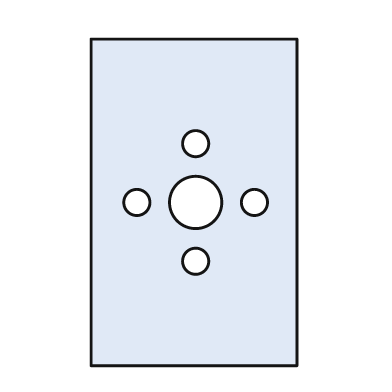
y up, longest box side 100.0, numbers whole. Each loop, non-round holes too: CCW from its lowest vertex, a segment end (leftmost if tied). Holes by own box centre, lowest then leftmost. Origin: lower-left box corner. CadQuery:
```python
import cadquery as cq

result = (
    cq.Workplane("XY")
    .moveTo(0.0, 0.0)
    .lineTo(63.0, 0.0)
    .lineTo(63.0, 100.0)
    .lineTo(0.0, 100.0)
    .close()
    .moveTo(32.0, 32.0)
    .circle(4.0)
    .moveTo(14.0, 50.0)
    .circle(4.0)
    .moveTo(32.0, 50.0)
    .circle(8.0)
    .moveTo(50.0, 50.0)
    .circle(4.0)
    .moveTo(32.0, 68.0)
    .circle(4.0)
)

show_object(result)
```